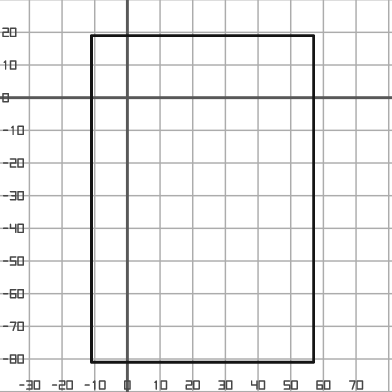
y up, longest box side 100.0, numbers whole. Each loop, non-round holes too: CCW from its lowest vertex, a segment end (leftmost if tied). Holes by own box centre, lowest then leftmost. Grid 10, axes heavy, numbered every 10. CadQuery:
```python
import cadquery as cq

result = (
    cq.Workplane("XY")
    .moveTo(-11.0, -81.0)
    .lineTo(57.0, -81.0)
    .lineTo(57.0, 19.0)
    .lineTo(-11.0, 19.0)
    .close()
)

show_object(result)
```